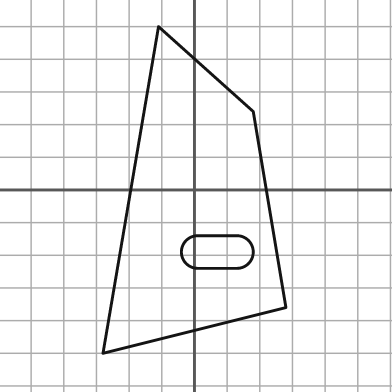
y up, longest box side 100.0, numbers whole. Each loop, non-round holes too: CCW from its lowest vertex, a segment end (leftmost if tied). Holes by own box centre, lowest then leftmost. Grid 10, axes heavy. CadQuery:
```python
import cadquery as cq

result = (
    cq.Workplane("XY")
    .moveTo(-28.0, -50.0)
    .lineTo(28.0, -36.0)
    .lineTo(18.0, 24.0)
    .lineTo(-11.0, 50.0)
    .close()
    .moveTo(1.0, -24.0)
    .lineTo(13.0, -24.0)
    .threePointArc((18.0, -19.0), (13.0, -14.0))
    .lineTo(1.0, -14.0)
    .threePointArc((-4.0, -19.0), (1.0, -24.0))
    .close()
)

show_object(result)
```